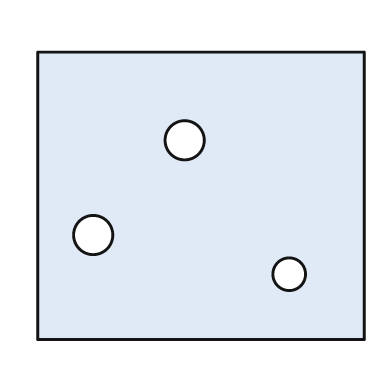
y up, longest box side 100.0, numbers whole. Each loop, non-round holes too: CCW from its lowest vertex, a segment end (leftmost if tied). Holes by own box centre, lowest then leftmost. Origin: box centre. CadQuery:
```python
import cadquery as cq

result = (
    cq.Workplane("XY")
    .moveTo(-50.0, -44.0)
    .lineTo(50.0, -44.0)
    .lineTo(50.0, 44.0)
    .lineTo(-50.0, 44.0)
    .close()
    .moveTo(27.0, -24.0)
    .circle(5.0)
    .moveTo(-33.0, -12.0)
    .circle(6.0)
    .moveTo(-5.0, 17.0)
    .circle(6.0)
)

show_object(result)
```